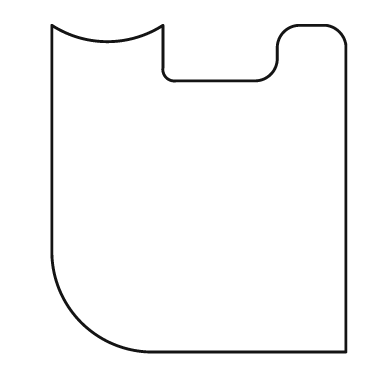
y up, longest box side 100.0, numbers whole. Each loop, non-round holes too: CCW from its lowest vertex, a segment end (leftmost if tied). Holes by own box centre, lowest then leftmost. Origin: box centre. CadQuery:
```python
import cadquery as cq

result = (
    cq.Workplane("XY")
    .moveTo(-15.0, -50.0)
    .lineTo(45.0, -50.0)
    .lineTo(45.0, 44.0)
    .threePointArc((43.0, 48.0), (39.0, 50.0))
    .lineTo(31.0, 50.0)
    .threePointArc((26.0, 48.0), (24.0, 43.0))
    .lineTo(24.0, 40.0)
    .threePointArc((22.0, 35.0), (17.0, 33.0))
    .lineTo(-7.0, 33.0)
    .threePointArc((-10.0, 34.0), (-11.0, 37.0))
    .lineTo(-11.0, 50.0)
    .threePointArc((-28.0, 45.0), (-45.0, 50.0))
    .lineTo(-45.0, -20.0)
    .threePointArc((-36.0, -41.0), (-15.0, -50.0))
    .close()
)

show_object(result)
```